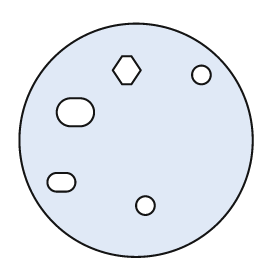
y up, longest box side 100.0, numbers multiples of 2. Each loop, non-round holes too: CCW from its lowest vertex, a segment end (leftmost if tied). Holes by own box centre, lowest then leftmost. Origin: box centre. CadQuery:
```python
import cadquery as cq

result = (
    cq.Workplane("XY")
    .moveTo(0.0, 0.0)
    .circle(50.0)
    .moveTo(4.0, -28.0)
    .circle(4.0)
    .moveTo(-34.0, -22.0)
    .lineTo(-30.0, -22.0)
    .threePointArc((-26.0, -18.0), (-30.0, -14.0))
    .lineTo(-34.0, -14.0)
    .threePointArc((-38.0, -18.0), (-34.0, -22.0))
    .close()
    .moveTo(-28.0, 6.0)
    .lineTo(-24.0, 6.0)
    .threePointArc((-18.0, 12.0), (-24.0, 18.0))
    .lineTo(-28.0, 18.0)
    .threePointArc((-34.0, 12.0), (-28.0, 6.0))
    .close()
    .moveTo(28.0, 28.0)
    .circle(4.0)
    .moveTo(-6.0, 24.0)
    .lineTo(-2.0, 24.0)
    .lineTo(2.0, 30.0)
    .lineTo(-2.0, 36.0)
    .lineTo(-6.0, 36.0)
    .lineTo(-10.0, 30.0)
    .close()
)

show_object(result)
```